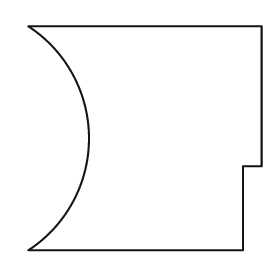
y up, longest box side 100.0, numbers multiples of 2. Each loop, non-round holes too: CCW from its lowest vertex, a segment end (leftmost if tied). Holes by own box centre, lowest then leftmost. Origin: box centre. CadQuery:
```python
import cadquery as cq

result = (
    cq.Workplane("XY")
    .moveTo(-50.0, -48.0)
    .lineTo(42.0, -48.0)
    .lineTo(42.0, -12.0)
    .lineTo(50.0, -12.0)
    .lineTo(50.0, 48.0)
    .lineTo(-50.0, 48.0)
    .threePointArc((-24.0, 0.0), (-50.0, -48.0))
    .close()
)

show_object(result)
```